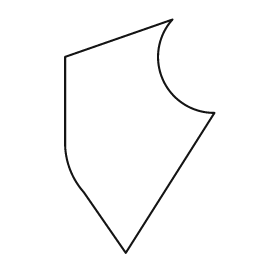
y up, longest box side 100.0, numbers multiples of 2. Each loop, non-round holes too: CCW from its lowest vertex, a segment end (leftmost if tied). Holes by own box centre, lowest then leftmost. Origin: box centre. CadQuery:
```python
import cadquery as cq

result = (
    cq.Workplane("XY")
    .moveTo(-6.0, -50.0)
    .lineTo(32.0, 10.0)
    .threePointArc((10.0, 24.0), (14.0, 50.0))
    .lineTo(-32.0, 34.0)
    .lineTo(-32.0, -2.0)
    .threePointArc((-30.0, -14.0), (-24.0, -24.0))
    .close()
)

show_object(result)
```